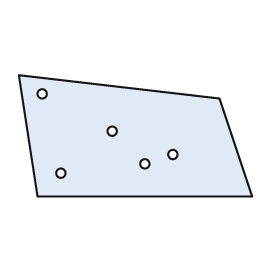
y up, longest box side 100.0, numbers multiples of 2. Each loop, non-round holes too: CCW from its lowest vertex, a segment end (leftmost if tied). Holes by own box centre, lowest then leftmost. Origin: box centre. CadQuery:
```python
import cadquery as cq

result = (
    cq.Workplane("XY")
    .moveTo(-42.0, -26.0)
    .lineTo(50.0, -26.0)
    .lineTo(36.0, 16.0)
    .lineTo(-50.0, 26.0)
    .close()
    .moveTo(-32.0, -16.0)
    .circle(2.0)
    .moveTo(4.0, -12.0)
    .circle(2.0)
    .moveTo(16.0, -8.0)
    .circle(2.0)
    .moveTo(-10.0, 2.0)
    .circle(2.0)
    .moveTo(-40.0, 18.0)
    .circle(2.0)
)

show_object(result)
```